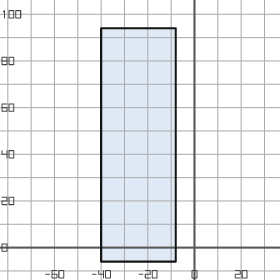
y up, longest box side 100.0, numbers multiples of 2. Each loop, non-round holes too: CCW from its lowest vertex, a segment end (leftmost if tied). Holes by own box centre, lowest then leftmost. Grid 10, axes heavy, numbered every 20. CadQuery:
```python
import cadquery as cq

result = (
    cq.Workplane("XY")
    .moveTo(-40.0, -6.0)
    .lineTo(-8.0, -6.0)
    .lineTo(-8.0, 94.0)
    .lineTo(-40.0, 94.0)
    .close()
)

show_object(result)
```